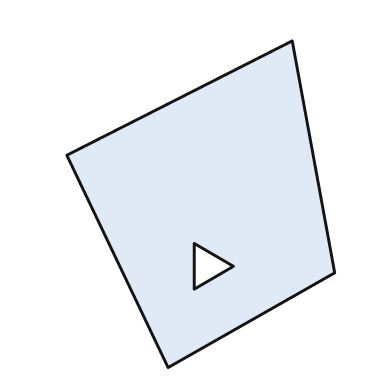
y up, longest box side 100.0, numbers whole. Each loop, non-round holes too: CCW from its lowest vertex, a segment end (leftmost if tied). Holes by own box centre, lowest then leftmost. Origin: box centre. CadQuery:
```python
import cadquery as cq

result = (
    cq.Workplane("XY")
    .moveTo(-10.0, -50.0)
    .lineTo(41.0, -21.0)
    .lineTo(28.0, 50.0)
    .lineTo(-41.0, 15.0)
    .close()
    .moveTo(-2.0, -26.0)
    .lineTo(10.0, -19.0)
    .lineTo(-2.0, -12.0)
    .close()
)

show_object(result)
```